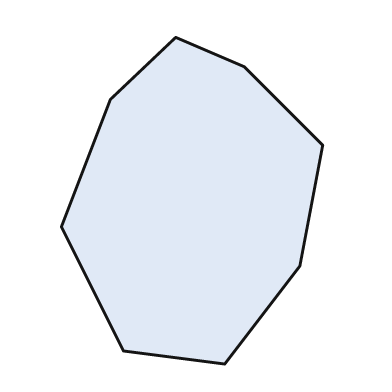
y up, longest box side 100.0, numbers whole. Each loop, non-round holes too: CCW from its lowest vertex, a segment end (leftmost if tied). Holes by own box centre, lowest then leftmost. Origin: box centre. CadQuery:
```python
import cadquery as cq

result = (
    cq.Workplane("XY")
    .moveTo(10.0, -50.0)
    .lineTo(33.0, -20.0)
    .lineTo(40.0, 17.0)
    .lineTo(16.0, 41.0)
    .lineTo(-5.0, 50.0)
    .lineTo(-25.0, 31.0)
    .lineTo(-40.0, -8.0)
    .lineTo(-21.0, -46.0)
    .close()
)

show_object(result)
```